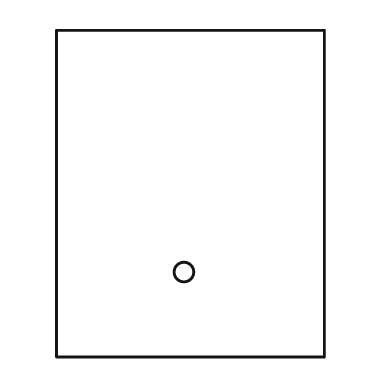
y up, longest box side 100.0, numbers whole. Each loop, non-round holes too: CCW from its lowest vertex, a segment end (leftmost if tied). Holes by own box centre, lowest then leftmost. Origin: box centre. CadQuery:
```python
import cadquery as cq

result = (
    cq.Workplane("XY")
    .moveTo(-41.0, -50.0)
    .lineTo(41.0, -50.0)
    .lineTo(41.0, 50.0)
    .lineTo(-41.0, 50.0)
    .close()
    .moveTo(-2.0, -24.0)
    .circle(3.0)
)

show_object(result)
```